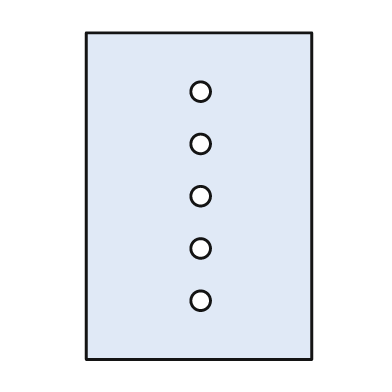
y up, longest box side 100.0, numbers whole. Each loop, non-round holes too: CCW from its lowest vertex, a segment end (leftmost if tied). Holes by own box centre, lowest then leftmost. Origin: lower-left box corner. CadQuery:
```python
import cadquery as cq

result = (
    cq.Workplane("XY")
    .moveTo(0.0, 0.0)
    .lineTo(69.0, 0.0)
    .lineTo(69.0, 100.0)
    .lineTo(0.0, 100.0)
    .close()
    .moveTo(35.0, 18.0)
    .circle(3.0)
    .moveTo(35.0, 34.0)
    .circle(3.0)
    .moveTo(35.0, 50.0)
    .circle(3.0)
    .moveTo(35.0, 66.0)
    .circle(3.0)
    .moveTo(35.0, 82.0)
    .circle(3.0)
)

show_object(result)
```